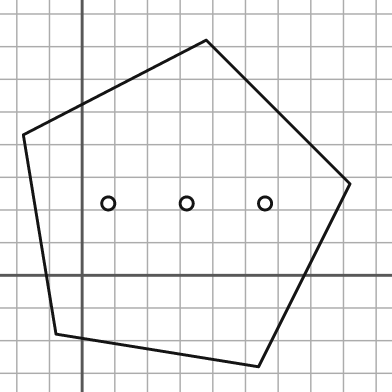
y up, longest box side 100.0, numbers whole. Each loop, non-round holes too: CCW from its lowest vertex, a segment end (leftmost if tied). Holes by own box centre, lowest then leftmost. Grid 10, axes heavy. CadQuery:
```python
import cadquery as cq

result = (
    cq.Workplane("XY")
    .moveTo(54.0, -28.0)
    .lineTo(82.0, 28.0)
    .lineTo(38.0, 72.0)
    .lineTo(-18.0, 43.0)
    .lineTo(-8.0, -18.0)
    .close()
    .moveTo(8.0, 22.0)
    .circle(2.0)
    .moveTo(32.0, 22.0)
    .circle(2.0)
    .moveTo(56.0, 22.0)
    .circle(2.0)
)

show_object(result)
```